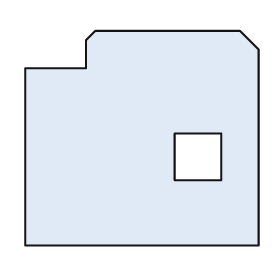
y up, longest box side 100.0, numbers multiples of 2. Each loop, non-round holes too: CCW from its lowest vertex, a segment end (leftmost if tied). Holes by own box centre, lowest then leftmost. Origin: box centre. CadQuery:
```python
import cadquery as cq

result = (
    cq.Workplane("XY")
    .moveTo(-50.0, -46.0)
    .lineTo(50.0, -46.0)
    .lineTo(50.0, 38.0)
    .lineTo(42.0, 46.0)
    .lineTo(-20.0, 46.0)
    .lineTo(-24.0, 42.0)
    .lineTo(-24.0, 30.0)
    .lineTo(-50.0, 30.0)
    .close()
    .moveTo(14.0, -18.0)
    .lineTo(34.0, -18.0)
    .lineTo(34.0, 2.0)
    .lineTo(14.0, 2.0)
    .close()
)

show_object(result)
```